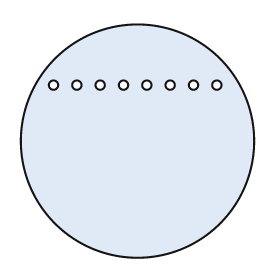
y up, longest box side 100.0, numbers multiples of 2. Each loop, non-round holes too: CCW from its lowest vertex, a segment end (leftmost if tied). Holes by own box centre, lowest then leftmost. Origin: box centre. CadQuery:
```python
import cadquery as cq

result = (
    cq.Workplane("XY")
    .moveTo(0.0, 0.0)
    .circle(50.0)
    .moveTo(-36.0, 24.0)
    .circle(2.0)
    .moveTo(-26.0, 24.0)
    .circle(2.0)
    .moveTo(-16.0, 24.0)
    .circle(2.0)
    .moveTo(-6.0, 24.0)
    .circle(2.0)
    .moveTo(4.0, 24.0)
    .circle(2.0)
    .moveTo(14.0, 24.0)
    .circle(2.0)
    .moveTo(24.0, 24.0)
    .circle(2.0)
    .moveTo(34.0, 24.0)
    .circle(2.0)
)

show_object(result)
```